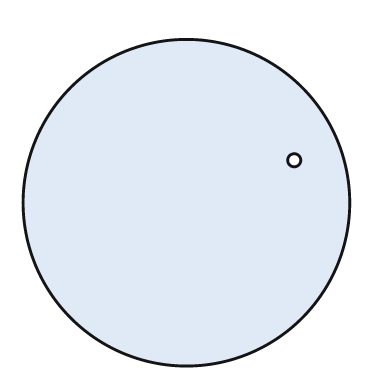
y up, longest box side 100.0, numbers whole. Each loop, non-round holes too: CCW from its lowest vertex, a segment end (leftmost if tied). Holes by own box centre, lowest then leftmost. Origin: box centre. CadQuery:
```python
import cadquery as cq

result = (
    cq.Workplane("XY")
    .moveTo(0.0, 0.0)
    .circle(50.0)
    .moveTo(33.0, 13.0)
    .circle(2.0)
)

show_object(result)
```